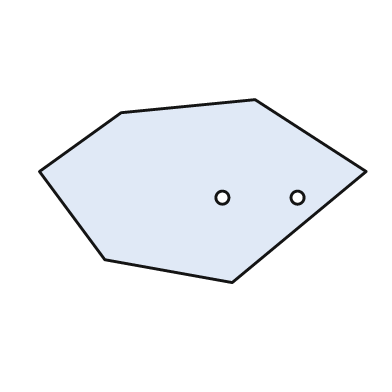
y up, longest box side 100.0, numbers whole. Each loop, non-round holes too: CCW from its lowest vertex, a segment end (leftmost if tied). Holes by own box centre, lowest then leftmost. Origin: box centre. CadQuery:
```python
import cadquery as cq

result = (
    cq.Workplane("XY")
    .moveTo(9.0, -28.0)
    .lineTo(50.0, 6.0)
    .lineTo(16.0, 28.0)
    .lineTo(-25.0, 24.0)
    .lineTo(-50.0, 6.0)
    .lineTo(-30.0, -21.0)
    .close()
    .moveTo(6.0, -2.0)
    .circle(2.0)
    .moveTo(29.0, -2.0)
    .circle(2.0)
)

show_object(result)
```